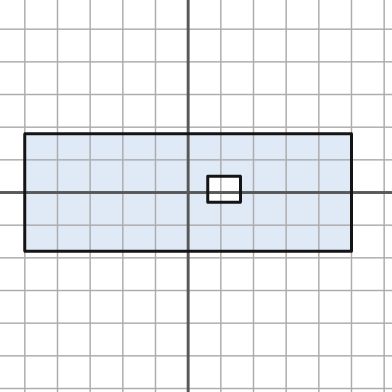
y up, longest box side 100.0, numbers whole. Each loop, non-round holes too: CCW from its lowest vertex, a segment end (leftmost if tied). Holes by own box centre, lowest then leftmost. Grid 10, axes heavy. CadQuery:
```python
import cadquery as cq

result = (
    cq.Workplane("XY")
    .moveTo(-50.0, -18.0)
    .lineTo(50.0, -18.0)
    .lineTo(50.0, 18.0)
    .lineTo(-50.0, 18.0)
    .close()
    .moveTo(6.0, -3.0)
    .lineTo(16.0, -3.0)
    .lineTo(16.0, 5.0)
    .lineTo(6.0, 5.0)
    .close()
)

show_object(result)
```